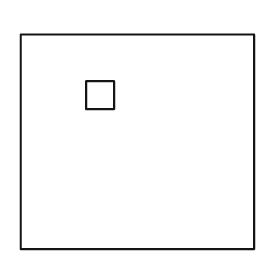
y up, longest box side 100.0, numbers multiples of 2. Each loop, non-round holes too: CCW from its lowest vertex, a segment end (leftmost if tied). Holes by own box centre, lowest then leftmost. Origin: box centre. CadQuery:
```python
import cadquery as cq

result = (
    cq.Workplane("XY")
    .moveTo(-50.0, -46.0)
    .lineTo(50.0, -46.0)
    .lineTo(50.0, 46.0)
    .lineTo(-50.0, 46.0)
    .close()
    .moveTo(-22.0, 14.0)
    .lineTo(-10.0, 14.0)
    .lineTo(-10.0, 26.0)
    .lineTo(-22.0, 26.0)
    .close()
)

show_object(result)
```